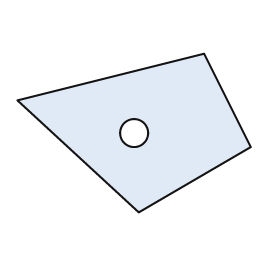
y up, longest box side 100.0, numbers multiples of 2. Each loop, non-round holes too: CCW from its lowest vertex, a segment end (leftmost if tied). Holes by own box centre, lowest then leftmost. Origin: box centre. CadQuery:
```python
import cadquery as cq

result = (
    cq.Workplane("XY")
    .moveTo(2.0, -34.0)
    .lineTo(50.0, -6.0)
    .lineTo(30.0, 34.0)
    .lineTo(-50.0, 14.0)
    .close()
    .moveTo(0.0, 0.0)
    .circle(6.0)
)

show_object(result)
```